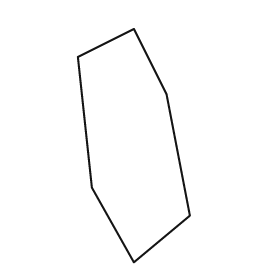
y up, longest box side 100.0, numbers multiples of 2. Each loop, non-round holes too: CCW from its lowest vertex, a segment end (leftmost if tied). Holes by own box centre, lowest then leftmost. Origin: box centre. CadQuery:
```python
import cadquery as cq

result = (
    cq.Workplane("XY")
    .moveTo(0.0, -50.0)
    .lineTo(24.0, -30.0)
    .lineTo(14.0, 22.0)
    .lineTo(0.0, 50.0)
    .lineTo(-24.0, 38.0)
    .lineTo(-18.0, -18.0)
    .close()
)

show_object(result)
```